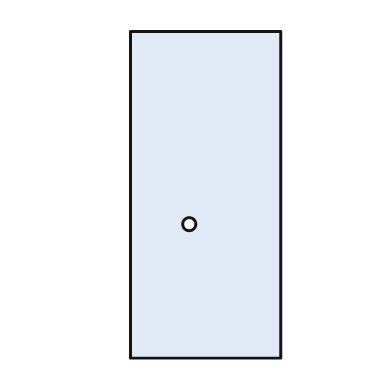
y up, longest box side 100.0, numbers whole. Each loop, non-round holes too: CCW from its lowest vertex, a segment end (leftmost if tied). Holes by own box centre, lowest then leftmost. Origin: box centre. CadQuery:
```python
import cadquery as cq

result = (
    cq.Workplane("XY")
    .moveTo(-23.0, -50.0)
    .lineTo(23.0, -50.0)
    .lineTo(23.0, 50.0)
    .lineTo(-23.0, 50.0)
    .close()
    .moveTo(-5.0, -9.0)
    .circle(2.0)
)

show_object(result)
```